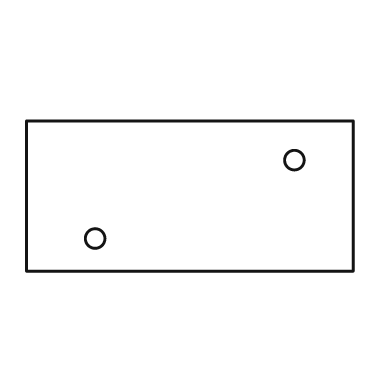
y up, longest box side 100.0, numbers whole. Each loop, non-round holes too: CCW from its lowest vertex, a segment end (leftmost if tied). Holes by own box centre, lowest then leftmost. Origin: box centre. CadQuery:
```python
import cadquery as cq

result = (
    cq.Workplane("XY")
    .moveTo(-50.0, -23.0)
    .lineTo(50.0, -23.0)
    .lineTo(50.0, 23.0)
    .lineTo(-50.0, 23.0)
    .close()
    .moveTo(-29.0, -13.0)
    .circle(3.0)
    .moveTo(32.0, 11.0)
    .circle(3.0)
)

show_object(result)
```